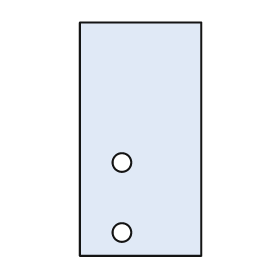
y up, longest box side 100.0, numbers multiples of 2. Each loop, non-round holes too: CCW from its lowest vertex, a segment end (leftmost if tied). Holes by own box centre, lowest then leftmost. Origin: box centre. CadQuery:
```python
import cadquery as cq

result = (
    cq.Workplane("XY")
    .moveTo(-26.0, -50.0)
    .lineTo(26.0, -50.0)
    .lineTo(26.0, 50.0)
    .lineTo(-26.0, 50.0)
    .close()
    .moveTo(-8.0, -40.0)
    .circle(4.0)
    .moveTo(-8.0, -10.0)
    .circle(4.0)
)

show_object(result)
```